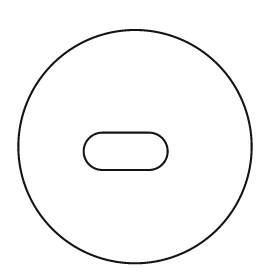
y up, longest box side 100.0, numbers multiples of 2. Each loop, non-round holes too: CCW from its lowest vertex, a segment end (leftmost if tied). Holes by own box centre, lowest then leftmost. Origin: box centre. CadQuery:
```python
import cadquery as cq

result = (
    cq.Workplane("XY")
    .moveTo(0.0, 0.0)
    .circle(50.0)
    .moveTo(-14.0, -10.0)
    .lineTo(6.0, -10.0)
    .threePointArc((14.0, -2.0), (6.0, 6.0))
    .lineTo(-14.0, 6.0)
    .threePointArc((-22.0, -2.0), (-14.0, -10.0))
    .close()
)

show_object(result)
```